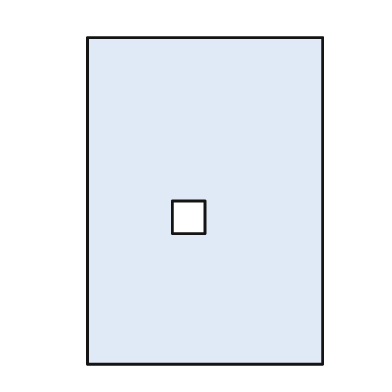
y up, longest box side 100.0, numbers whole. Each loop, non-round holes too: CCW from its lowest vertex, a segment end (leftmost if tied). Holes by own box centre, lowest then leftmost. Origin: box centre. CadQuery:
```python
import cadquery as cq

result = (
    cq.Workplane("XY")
    .moveTo(-36.0, -50.0)
    .lineTo(36.0, -50.0)
    .lineTo(36.0, 50.0)
    .lineTo(-36.0, 50.0)
    .close()
    .moveTo(-10.0, -10.0)
    .lineTo(0.0, -10.0)
    .lineTo(0.0, 0.0)
    .lineTo(-10.0, 0.0)
    .close()
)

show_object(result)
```